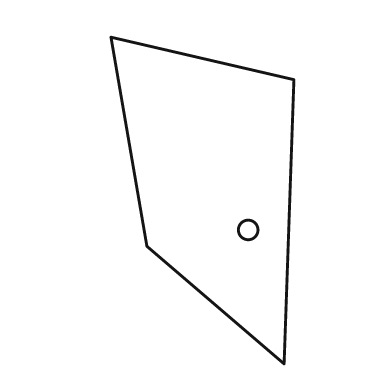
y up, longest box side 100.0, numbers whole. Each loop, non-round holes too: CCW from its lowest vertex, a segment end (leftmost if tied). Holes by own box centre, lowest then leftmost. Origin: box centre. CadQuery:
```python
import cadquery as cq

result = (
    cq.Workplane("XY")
    .moveTo(25.0, -50.0)
    .lineTo(28.0, 37.0)
    .lineTo(-28.0, 50.0)
    .lineTo(-17.0, -14.0)
    .close()
    .moveTo(14.0, -9.0)
    .circle(3.0)
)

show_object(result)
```